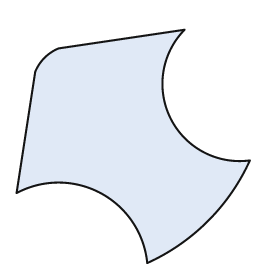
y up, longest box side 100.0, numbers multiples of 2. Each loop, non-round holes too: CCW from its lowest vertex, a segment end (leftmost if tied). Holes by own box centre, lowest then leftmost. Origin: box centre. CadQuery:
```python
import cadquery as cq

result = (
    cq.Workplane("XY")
    .moveTo(6.0, -50.0)
    .threePointArc((32.0, -32.0), (50.0, -6.0))
    .threePointArc((16.0, 12.0), (22.0, 50.0))
    .lineTo(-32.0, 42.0)
    .threePointArc((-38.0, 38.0), (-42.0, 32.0))
    .lineTo(-50.0, -20.0)
    .threePointArc((-14.0, -20.0), (6.0, -50.0))
    .close()
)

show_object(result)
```